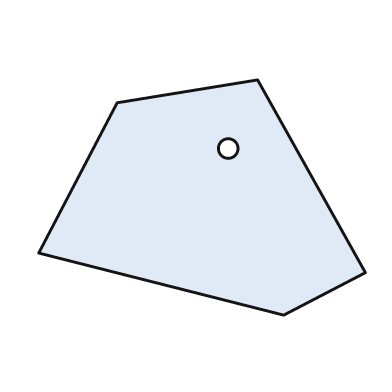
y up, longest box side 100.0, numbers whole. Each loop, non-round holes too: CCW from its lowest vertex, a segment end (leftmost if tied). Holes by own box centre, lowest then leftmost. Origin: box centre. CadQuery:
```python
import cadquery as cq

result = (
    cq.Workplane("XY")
    .moveTo(25.0, -36.0)
    .lineTo(50.0, -23.0)
    .lineTo(17.0, 36.0)
    .lineTo(-26.0, 29.0)
    .lineTo(-50.0, -17.0)
    .close()
    .moveTo(8.0, 15.0)
    .circle(3.0)
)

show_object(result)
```